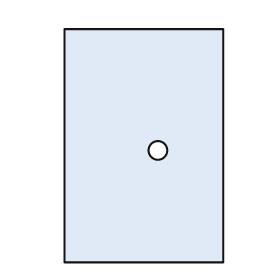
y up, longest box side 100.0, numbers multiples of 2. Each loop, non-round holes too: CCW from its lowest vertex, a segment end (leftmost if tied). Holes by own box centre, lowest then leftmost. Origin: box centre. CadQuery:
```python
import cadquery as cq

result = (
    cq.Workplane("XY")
    .moveTo(-34.0, -50.0)
    .lineTo(34.0, -50.0)
    .lineTo(34.0, 50.0)
    .lineTo(-34.0, 50.0)
    .close()
    .moveTo(6.0, -2.0)
    .circle(4.0)
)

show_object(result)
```